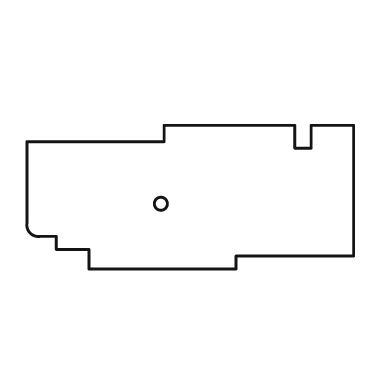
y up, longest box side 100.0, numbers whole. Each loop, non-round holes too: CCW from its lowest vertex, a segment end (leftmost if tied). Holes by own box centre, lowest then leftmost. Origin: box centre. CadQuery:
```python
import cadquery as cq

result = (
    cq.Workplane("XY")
    .moveTo(-31.0, -22.0)
    .lineTo(14.0, -22.0)
    .lineTo(14.0, -18.0)
    .lineTo(50.0, -18.0)
    .lineTo(50.0, 22.0)
    .lineTo(37.0, 22.0)
    .lineTo(37.0, 15.0)
    .lineTo(32.0, 15.0)
    .lineTo(32.0, 22.0)
    .lineTo(-8.0, 22.0)
    .lineTo(-8.0, 17.0)
    .lineTo(-50.0, 17.0)
    .lineTo(-50.0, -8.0)
    .threePointArc((-49.0, -11.0), (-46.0, -12.0))
    .lineTo(-41.0, -12.0)
    .lineTo(-41.0, -16.0)
    .lineTo(-31.0, -16.0)
    .close()
    .moveTo(-9.0, -2.0)
    .circle(2.0)
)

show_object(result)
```